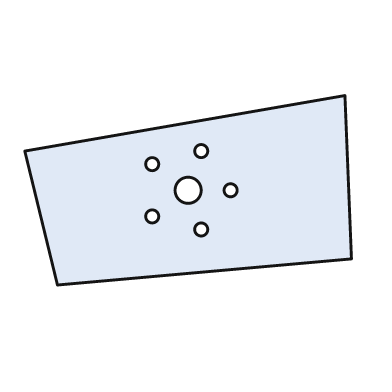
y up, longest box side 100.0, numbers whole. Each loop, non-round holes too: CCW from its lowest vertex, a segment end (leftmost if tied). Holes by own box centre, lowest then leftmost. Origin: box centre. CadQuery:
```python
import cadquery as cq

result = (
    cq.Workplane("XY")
    .moveTo(-40.0, -29.0)
    .lineTo(50.0, -21.0)
    .lineTo(48.0, 29.0)
    .lineTo(-50.0, 12.0)
    .close()
    .moveTo(4.0, -12.0)
    .circle(2.0)
    .moveTo(-11.0, -8.0)
    .circle(2.0)
    .moveTo(0.0, 0.0)
    .circle(4.0)
    .moveTo(13.0, 0.0)
    .circle(2.0)
    .moveTo(-11.0, 8.0)
    .circle(2.0)
    .moveTo(4.0, 12.0)
    .circle(2.0)
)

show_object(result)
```